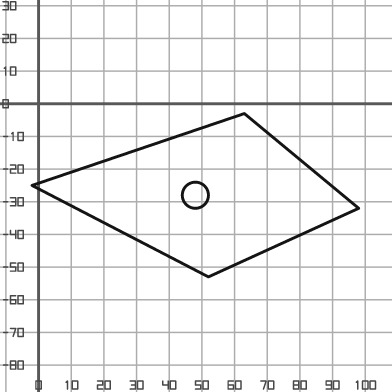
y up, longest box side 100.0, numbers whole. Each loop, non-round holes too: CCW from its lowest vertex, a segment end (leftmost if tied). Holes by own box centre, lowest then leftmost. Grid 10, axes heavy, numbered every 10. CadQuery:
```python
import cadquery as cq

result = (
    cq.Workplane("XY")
    .moveTo(52.0, -53.0)
    .lineTo(98.0, -32.0)
    .lineTo(63.0, -3.0)
    .lineTo(-2.0, -25.0)
    .close()
    .moveTo(48.0, -28.0)
    .circle(4.0)
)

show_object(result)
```